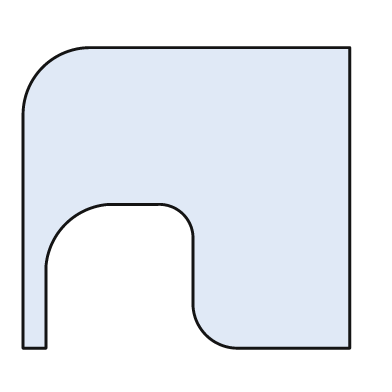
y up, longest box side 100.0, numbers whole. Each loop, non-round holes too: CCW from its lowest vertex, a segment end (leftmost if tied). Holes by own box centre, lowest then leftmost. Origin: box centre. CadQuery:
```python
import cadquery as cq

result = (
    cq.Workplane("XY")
    .moveTo(-50.0, -46.0)
    .lineTo(-43.0, -46.0)
    .lineTo(-43.0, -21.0)
    .threePointArc((-37.0, -8.0), (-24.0, -2.0))
    .lineTo(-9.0, -2.0)
    .threePointArc((-1.0, -5.0), (2.0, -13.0))
    .lineTo(2.0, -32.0)
    .threePointArc((6.0, -42.0), (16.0, -46.0))
    .lineTo(50.0, -46.0)
    .lineTo(50.0, 46.0)
    .lineTo(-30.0, 46.0)
    .threePointArc((-44.0, 40.0), (-50.0, 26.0))
    .close()
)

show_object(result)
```